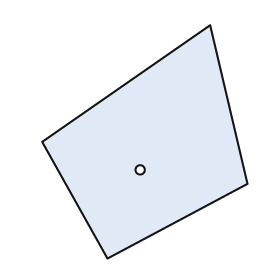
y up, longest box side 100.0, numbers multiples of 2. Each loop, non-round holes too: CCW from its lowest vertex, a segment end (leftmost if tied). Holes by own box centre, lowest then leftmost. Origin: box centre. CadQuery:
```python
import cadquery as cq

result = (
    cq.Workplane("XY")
    .moveTo(-16.0, -50.0)
    .lineTo(44.0, -18.0)
    .lineTo(28.0, 50.0)
    .lineTo(-44.0, 0.0)
    .close()
    .moveTo(-2.0, -12.0)
    .circle(2.0)
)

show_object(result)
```